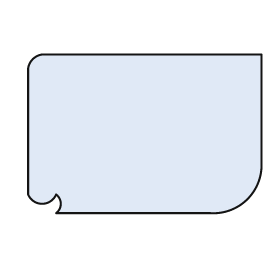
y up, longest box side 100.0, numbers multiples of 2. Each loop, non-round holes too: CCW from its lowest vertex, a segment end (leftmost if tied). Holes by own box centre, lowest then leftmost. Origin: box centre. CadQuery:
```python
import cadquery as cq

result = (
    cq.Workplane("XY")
    .moveTo(-38.0, -34.0)
    .lineTo(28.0, -34.0)
    .threePointArc((44.0, -28.0), (50.0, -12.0))
    .lineTo(50.0, 34.0)
    .lineTo(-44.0, 34.0)
    .threePointArc((-48.0, 32.0), (-50.0, 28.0))
    .lineTo(-50.0, -26.0)
    .threePointArc((-44.0, -30.0), (-38.0, -26.0))
    .threePointArc((-36.0, -30.0), (-38.0, -34.0))
    .close()
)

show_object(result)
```